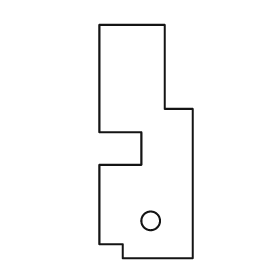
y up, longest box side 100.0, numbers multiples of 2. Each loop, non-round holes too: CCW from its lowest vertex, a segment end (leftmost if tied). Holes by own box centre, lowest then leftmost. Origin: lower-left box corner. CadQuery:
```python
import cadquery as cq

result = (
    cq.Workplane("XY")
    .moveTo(10.0, 0.0)
    .lineTo(40.0, 0.0)
    .lineTo(40.0, 64.0)
    .lineTo(28.0, 64.0)
    .lineTo(28.0, 100.0)
    .lineTo(0.0, 100.0)
    .lineTo(0.0, 54.0)
    .lineTo(18.0, 54.0)
    .lineTo(18.0, 40.0)
    .lineTo(0.0, 40.0)
    .lineTo(0.0, 6.0)
    .lineTo(10.0, 6.0)
    .close()
    .moveTo(22.0, 16.0)
    .circle(4.0)
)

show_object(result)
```